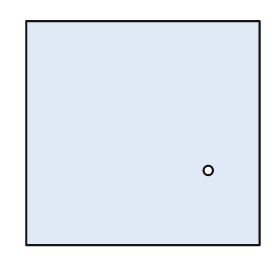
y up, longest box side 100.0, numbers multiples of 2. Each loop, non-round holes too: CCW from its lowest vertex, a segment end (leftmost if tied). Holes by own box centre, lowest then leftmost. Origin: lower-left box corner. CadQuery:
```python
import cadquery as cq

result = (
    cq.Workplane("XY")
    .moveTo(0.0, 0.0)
    .lineTo(100.0, 0.0)
    .lineTo(100.0, 96.0)
    .lineTo(0.0, 96.0)
    .close()
    .moveTo(78.0, 32.0)
    .circle(2.0)
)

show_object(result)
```